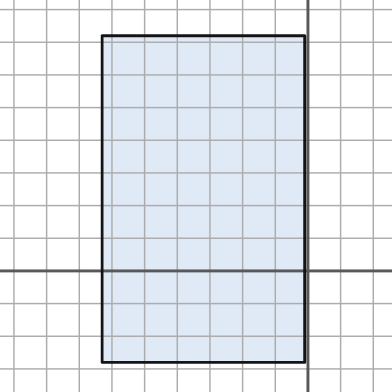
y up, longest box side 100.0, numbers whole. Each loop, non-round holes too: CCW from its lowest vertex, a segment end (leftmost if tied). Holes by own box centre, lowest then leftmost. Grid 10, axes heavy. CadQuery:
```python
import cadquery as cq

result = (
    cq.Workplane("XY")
    .moveTo(-63.0, -28.0)
    .lineTo(-1.0, -28.0)
    .lineTo(-1.0, 72.0)
    .lineTo(-63.0, 72.0)
    .close()
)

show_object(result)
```